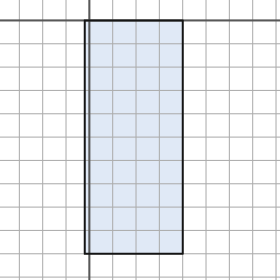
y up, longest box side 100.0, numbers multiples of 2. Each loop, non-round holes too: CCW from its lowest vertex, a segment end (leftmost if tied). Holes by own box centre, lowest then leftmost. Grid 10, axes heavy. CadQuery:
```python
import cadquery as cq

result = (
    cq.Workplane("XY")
    .moveTo(-2.0, -100.0)
    .lineTo(40.0, -100.0)
    .lineTo(40.0, 0.0)
    .lineTo(-2.0, 0.0)
    .close()
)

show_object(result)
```